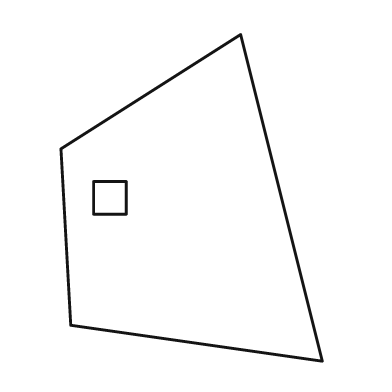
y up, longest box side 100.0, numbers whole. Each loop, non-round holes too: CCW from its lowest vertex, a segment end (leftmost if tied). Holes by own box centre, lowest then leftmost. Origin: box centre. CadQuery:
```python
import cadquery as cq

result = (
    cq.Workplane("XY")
    .moveTo(40.0, -50.0)
    .lineTo(15.0, 50.0)
    .lineTo(-40.0, 15.0)
    .lineTo(-37.0, -39.0)
    .close()
    .moveTo(-30.0, -5.0)
    .lineTo(-20.0, -5.0)
    .lineTo(-20.0, 5.0)
    .lineTo(-30.0, 5.0)
    .close()
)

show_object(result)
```